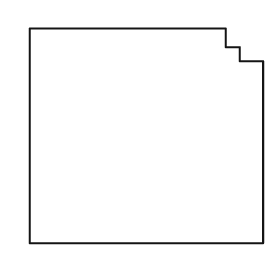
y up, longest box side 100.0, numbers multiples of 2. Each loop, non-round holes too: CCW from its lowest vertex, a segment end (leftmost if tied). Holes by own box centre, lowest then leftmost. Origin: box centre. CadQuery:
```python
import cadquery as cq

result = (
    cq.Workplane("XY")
    .moveTo(-50.0, -46.0)
    .lineTo(50.0, -46.0)
    .lineTo(50.0, 32.0)
    .lineTo(40.0, 32.0)
    .lineTo(40.0, 38.0)
    .lineTo(34.0, 38.0)
    .lineTo(34.0, 46.0)
    .lineTo(-50.0, 46.0)
    .close()
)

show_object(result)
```